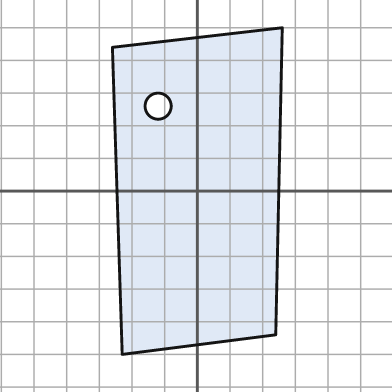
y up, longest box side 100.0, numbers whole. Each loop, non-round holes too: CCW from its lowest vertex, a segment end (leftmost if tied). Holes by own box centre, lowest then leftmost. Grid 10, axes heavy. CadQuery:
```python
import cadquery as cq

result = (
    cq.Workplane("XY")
    .moveTo(-23.0, -50.0)
    .lineTo(24.0, -44.0)
    .lineTo(26.0, 50.0)
    .lineTo(-26.0, 44.0)
    .close()
    .moveTo(-12.0, 26.0)
    .circle(4.0)
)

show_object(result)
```